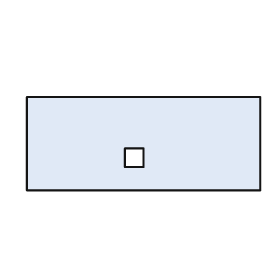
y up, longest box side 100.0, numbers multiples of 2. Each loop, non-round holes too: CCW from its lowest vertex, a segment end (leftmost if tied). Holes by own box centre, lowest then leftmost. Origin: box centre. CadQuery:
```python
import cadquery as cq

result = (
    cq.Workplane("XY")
    .moveTo(-50.0, -20.0)
    .lineTo(50.0, -20.0)
    .lineTo(50.0, 20.0)
    .lineTo(-50.0, 20.0)
    .close()
    .moveTo(-8.0, -10.0)
    .lineTo(0.0, -10.0)
    .lineTo(0.0, -2.0)
    .lineTo(-8.0, -2.0)
    .close()
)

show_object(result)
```